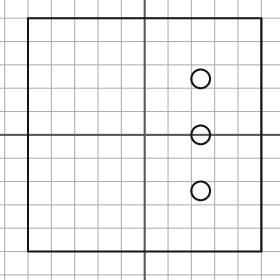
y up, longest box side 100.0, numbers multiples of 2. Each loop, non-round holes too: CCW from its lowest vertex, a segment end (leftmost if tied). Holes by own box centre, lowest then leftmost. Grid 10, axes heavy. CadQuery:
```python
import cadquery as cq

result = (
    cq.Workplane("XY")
    .moveTo(-50.0, -50.0)
    .lineTo(50.0, -50.0)
    .lineTo(50.0, 50.0)
    .lineTo(-50.0, 50.0)
    .close()
    .moveTo(24.0, -24.0)
    .circle(4.0)
    .moveTo(24.0, 0.0)
    .circle(4.0)
    .moveTo(24.0, 24.0)
    .circle(4.0)
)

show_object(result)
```